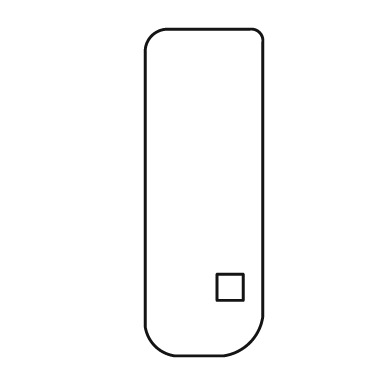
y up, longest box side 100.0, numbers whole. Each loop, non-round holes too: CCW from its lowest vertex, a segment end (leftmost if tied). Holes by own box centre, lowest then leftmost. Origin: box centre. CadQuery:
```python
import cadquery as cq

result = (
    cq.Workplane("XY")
    .moveTo(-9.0, -50.0)
    .lineTo(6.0, -50.0)
    .threePointArc((14.0, -46.0), (18.0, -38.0))
    .lineTo(18.0, 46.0)
    .threePointArc((17.0, 49.0), (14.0, 50.0))
    .lineTo(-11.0, 50.0)
    .threePointArc((-16.0, 48.0), (-18.0, 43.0))
    .lineTo(-18.0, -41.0)
    .threePointArc((-15.0, -47.0), (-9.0, -50.0))
    .close()
    .moveTo(4.0, -33.0)
    .lineTo(12.0, -33.0)
    .lineTo(12.0, -25.0)
    .lineTo(4.0, -25.0)
    .close()
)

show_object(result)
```